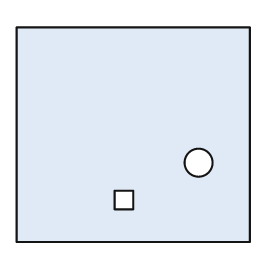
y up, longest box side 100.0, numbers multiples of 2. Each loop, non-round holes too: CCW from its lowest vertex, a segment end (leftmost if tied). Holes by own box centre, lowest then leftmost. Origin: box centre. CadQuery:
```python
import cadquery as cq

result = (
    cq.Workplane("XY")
    .moveTo(-50.0, -46.0)
    .lineTo(50.0, -46.0)
    .lineTo(50.0, 46.0)
    .lineTo(-50.0, 46.0)
    .close()
    .moveTo(-8.0, -32.0)
    .lineTo(0.0, -32.0)
    .lineTo(0.0, -24.0)
    .lineTo(-8.0, -24.0)
    .close()
    .moveTo(28.0, -12.0)
    .circle(6.0)
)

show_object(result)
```